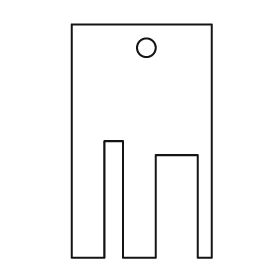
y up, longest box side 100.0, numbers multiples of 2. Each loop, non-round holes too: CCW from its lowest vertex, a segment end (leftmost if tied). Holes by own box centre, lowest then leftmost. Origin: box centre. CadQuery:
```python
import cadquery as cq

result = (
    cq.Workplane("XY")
    .moveTo(-30.0, -50.0)
    .lineTo(-16.0, -50.0)
    .lineTo(-16.0, 0.0)
    .lineTo(-8.0, 0.0)
    .lineTo(-8.0, -50.0)
    .lineTo(6.0, -50.0)
    .lineTo(6.0, -6.0)
    .lineTo(24.0, -6.0)
    .lineTo(24.0, -50.0)
    .lineTo(30.0, -50.0)
    .lineTo(30.0, 50.0)
    .lineTo(-30.0, 50.0)
    .close()
    .moveTo(2.0, 40.0)
    .circle(4.0)
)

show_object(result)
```